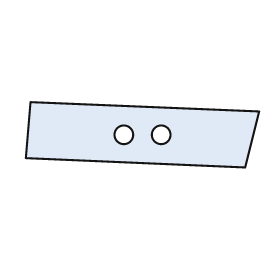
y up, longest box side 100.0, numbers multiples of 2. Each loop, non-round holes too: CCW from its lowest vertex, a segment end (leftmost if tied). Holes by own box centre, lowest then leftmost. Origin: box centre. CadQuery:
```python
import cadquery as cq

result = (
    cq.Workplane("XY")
    .moveTo(44.0, -14.0)
    .lineTo(50.0, 10.0)
    .lineTo(-48.0, 14.0)
    .lineTo(-50.0, -10.0)
    .close()
    .moveTo(-8.0, 0.0)
    .circle(4.0)
    .moveTo(8.0, 0.0)
    .circle(4.0)
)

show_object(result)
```